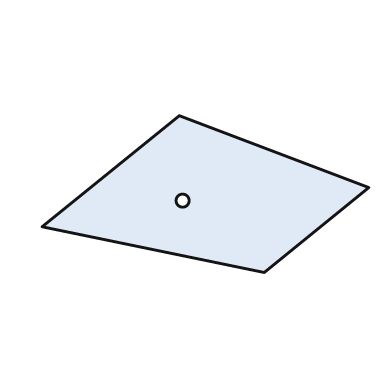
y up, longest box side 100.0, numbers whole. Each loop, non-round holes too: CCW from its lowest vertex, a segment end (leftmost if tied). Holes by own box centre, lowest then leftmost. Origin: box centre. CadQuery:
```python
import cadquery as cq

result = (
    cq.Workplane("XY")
    .moveTo(18.0, -24.0)
    .lineTo(50.0, 2.0)
    .lineTo(-8.0, 24.0)
    .lineTo(-50.0, -10.0)
    .close()
    .moveTo(-7.0, -2.0)
    .circle(2.0)
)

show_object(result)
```